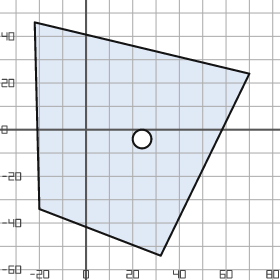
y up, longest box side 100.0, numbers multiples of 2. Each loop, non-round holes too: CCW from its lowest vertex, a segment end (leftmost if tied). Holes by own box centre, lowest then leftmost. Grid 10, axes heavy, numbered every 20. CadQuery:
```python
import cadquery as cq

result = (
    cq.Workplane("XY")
    .moveTo(32.0, -54.0)
    .lineTo(70.0, 24.0)
    .lineTo(-22.0, 46.0)
    .lineTo(-20.0, -34.0)
    .close()
    .moveTo(24.0, -4.0)
    .circle(4.0)
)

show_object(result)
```